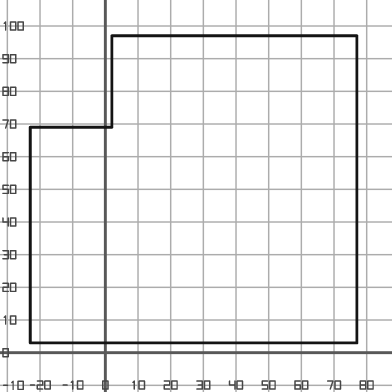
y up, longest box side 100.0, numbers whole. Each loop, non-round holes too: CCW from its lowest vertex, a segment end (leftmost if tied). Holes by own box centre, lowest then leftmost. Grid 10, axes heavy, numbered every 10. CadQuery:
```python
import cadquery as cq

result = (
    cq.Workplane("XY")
    .moveTo(-23.0, 3.0)
    .lineTo(77.0, 3.0)
    .lineTo(77.0, 97.0)
    .lineTo(2.0, 97.0)
    .lineTo(2.0, 69.0)
    .lineTo(-23.0, 69.0)
    .close()
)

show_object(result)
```